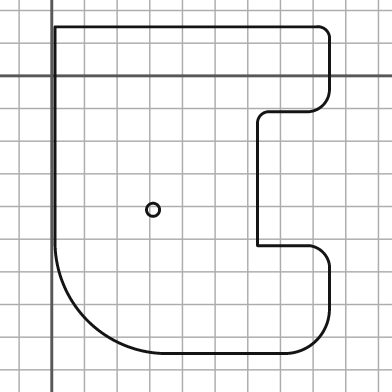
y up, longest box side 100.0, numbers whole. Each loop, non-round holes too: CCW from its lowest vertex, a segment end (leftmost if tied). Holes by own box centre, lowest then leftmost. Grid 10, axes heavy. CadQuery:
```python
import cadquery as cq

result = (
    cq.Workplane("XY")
    .moveTo(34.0, -85.0)
    .lineTo(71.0, -85.0)
    .threePointArc((81.0, -81.0), (85.0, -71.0))
    .lineTo(85.0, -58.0)
    .threePointArc((83.0, -54.0), (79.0, -52.0))
    .lineTo(63.0, -52.0)
    .lineTo(63.0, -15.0)
    .threePointArc((64.0, -12.0), (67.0, -11.0))
    .lineTo(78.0, -11.0)
    .threePointArc((83.0, -9.0), (85.0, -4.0))
    .lineTo(85.0, 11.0)
    .threePointArc((84.0, 14.0), (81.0, 15.0))
    .lineTo(1.0, 15.0)
    .lineTo(1.0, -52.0)
    .threePointArc((11.0, -75.0), (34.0, -85.0))
    .close()
    .moveTo(31.0, -41.0)
    .circle(2.0)
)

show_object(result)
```